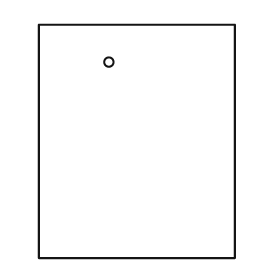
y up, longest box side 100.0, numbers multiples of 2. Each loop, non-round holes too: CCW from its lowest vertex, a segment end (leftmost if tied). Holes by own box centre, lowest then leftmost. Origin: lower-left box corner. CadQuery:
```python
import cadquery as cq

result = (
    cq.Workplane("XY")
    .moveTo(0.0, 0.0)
    .lineTo(84.0, 0.0)
    .lineTo(84.0, 100.0)
    .lineTo(0.0, 100.0)
    .close()
    .moveTo(30.0, 84.0)
    .circle(2.0)
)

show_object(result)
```